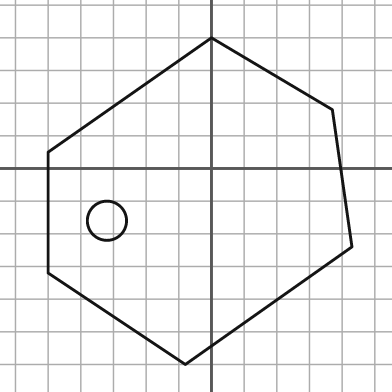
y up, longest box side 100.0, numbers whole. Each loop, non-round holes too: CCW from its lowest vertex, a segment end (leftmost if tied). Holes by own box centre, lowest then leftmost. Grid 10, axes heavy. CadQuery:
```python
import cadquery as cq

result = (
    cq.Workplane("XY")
    .moveTo(-8.0, -60.0)
    .lineTo(43.0, -24.0)
    .lineTo(37.0, 18.0)
    .lineTo(0.0, 40.0)
    .lineTo(-50.0, 5.0)
    .lineTo(-50.0, -32.0)
    .close()
    .moveTo(-32.0, -16.0)
    .circle(6.0)
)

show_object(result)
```